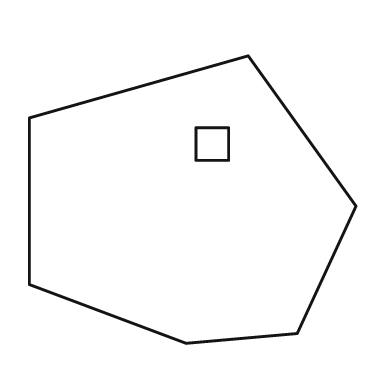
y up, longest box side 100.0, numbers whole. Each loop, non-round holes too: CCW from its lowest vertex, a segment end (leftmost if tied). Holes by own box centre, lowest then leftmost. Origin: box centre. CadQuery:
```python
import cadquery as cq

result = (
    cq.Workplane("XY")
    .moveTo(-2.0, -44.0)
    .lineTo(32.0, -41.0)
    .lineTo(50.0, -2.0)
    .lineTo(17.0, 44.0)
    .lineTo(-50.0, 25.0)
    .lineTo(-50.0, -26.0)
    .close()
    .moveTo(1.0, 12.0)
    .lineTo(11.0, 12.0)
    .lineTo(11.0, 22.0)
    .lineTo(1.0, 22.0)
    .close()
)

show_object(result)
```